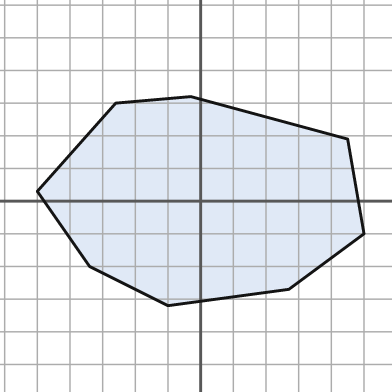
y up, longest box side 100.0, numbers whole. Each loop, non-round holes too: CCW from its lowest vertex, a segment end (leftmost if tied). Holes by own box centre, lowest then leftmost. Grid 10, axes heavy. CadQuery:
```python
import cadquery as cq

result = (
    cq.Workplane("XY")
    .moveTo(-10.0, -32.0)
    .lineTo(27.0, -27.0)
    .lineTo(50.0, -10.0)
    .lineTo(45.0, 19.0)
    .lineTo(-3.0, 32.0)
    .lineTo(-26.0, 30.0)
    .lineTo(-50.0, 3.0)
    .lineTo(-34.0, -20.0)
    .close()
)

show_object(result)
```